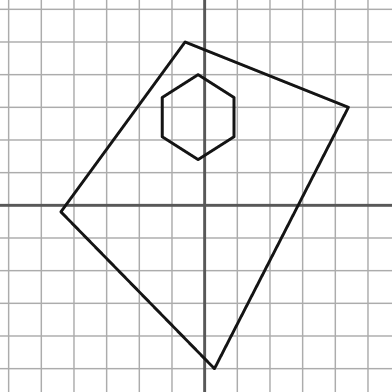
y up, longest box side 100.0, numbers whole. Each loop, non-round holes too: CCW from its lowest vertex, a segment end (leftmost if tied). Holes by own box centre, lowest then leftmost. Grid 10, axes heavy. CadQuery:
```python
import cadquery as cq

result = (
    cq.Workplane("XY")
    .moveTo(3.0, -50.0)
    .lineTo(44.0, 30.0)
    .lineTo(-6.0, 50.0)
    .lineTo(-44.0, -2.0)
    .close()
    .moveTo(-2.0, 14.0)
    .lineTo(9.0, 21.0)
    .lineTo(9.0, 33.0)
    .lineTo(-2.0, 40.0)
    .lineTo(-13.0, 33.0)
    .lineTo(-13.0, 21.0)
    .close()
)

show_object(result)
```